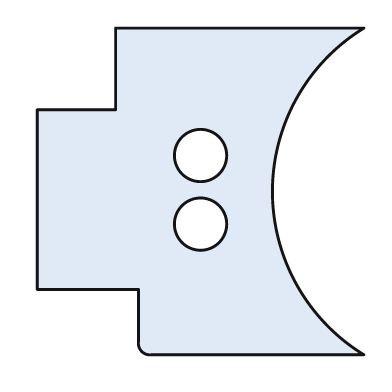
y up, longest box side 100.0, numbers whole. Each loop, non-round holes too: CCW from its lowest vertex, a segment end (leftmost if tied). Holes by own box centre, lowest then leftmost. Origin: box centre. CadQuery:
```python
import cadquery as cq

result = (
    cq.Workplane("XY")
    .moveTo(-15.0, -50.0)
    .lineTo(50.0, -50.0)
    .threePointArc((22.0, 0.0), (50.0, 50.0))
    .lineTo(-26.0, 50.0)
    .lineTo(-26.0, 25.0)
    .lineTo(-50.0, 25.0)
    .lineTo(-50.0, -30.0)
    .lineTo(-19.0, -30.0)
    .lineTo(-19.0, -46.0)
    .threePointArc((-18.0, -49.0), (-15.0, -50.0))
    .close()
    .moveTo(0.0, -10.0)
    .circle(8.0)
    .moveTo(0.0, 11.0)
    .circle(8.0)
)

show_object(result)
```